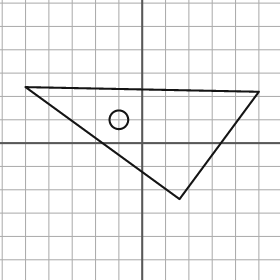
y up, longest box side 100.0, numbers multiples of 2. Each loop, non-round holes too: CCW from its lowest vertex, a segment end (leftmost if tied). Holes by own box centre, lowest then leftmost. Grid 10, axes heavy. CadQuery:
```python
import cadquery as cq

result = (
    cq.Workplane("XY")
    .moveTo(16.0, -24.0)
    .lineTo(50.0, 22.0)
    .lineTo(-50.0, 24.0)
    .close()
    .moveTo(-10.0, 10.0)
    .circle(4.0)
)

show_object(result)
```